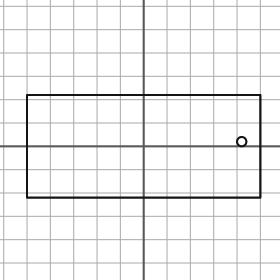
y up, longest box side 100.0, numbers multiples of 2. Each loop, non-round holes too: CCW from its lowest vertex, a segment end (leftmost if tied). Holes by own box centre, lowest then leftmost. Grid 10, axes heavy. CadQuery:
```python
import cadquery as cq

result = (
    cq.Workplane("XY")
    .moveTo(-50.0, -22.0)
    .lineTo(50.0, -22.0)
    .lineTo(50.0, 22.0)
    .lineTo(-50.0, 22.0)
    .close()
    .moveTo(42.0, 2.0)
    .circle(2.0)
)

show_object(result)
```